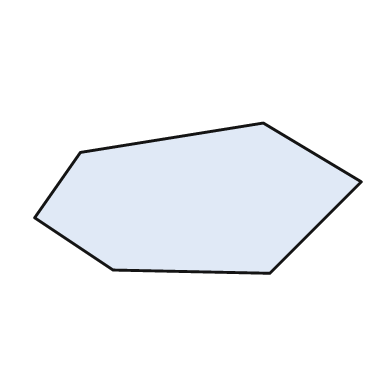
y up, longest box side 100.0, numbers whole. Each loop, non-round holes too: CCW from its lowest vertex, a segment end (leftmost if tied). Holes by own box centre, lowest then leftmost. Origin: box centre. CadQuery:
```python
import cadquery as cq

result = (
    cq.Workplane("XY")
    .moveTo(22.0, -23.0)
    .lineTo(50.0, 5.0)
    .lineTo(20.0, 23.0)
    .lineTo(-36.0, 14.0)
    .lineTo(-50.0, -6.0)
    .lineTo(-26.0, -22.0)
    .close()
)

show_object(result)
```